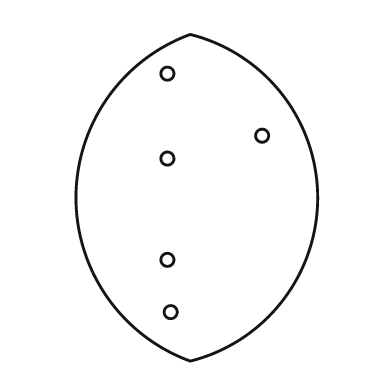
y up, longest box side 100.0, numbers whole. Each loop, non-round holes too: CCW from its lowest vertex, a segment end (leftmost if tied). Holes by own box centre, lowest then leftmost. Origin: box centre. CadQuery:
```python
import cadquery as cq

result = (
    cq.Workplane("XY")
    .moveTo(-2.0, -50.0)
    .threePointArc((37.0, 0.0), (-2.0, 50.0))
    .threePointArc((-37.0, 0.0), (-2.0, -50.0))
    .close()
    .moveTo(-8.0, -35.0)
    .circle(2.0)
    .moveTo(-9.0, -19.0)
    .circle(2.0)
    .moveTo(-9.0, 12.0)
    .circle(2.0)
    .moveTo(20.0, 19.0)
    .circle(2.0)
    .moveTo(-9.0, 38.0)
    .circle(2.0)
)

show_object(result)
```